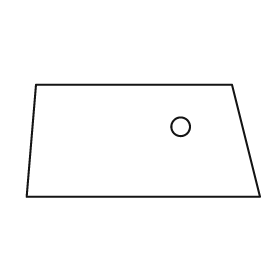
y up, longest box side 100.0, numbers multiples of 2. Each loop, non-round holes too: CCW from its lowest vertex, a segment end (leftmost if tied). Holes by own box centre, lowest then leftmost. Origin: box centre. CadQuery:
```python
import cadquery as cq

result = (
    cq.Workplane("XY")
    .moveTo(-50.0, -24.0)
    .lineTo(50.0, -24.0)
    .lineTo(38.0, 24.0)
    .lineTo(-46.0, 24.0)
    .close()
    .moveTo(16.0, 6.0)
    .circle(4.0)
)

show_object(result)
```